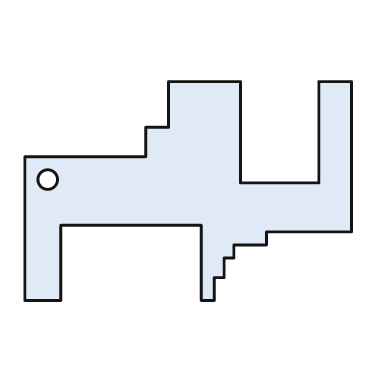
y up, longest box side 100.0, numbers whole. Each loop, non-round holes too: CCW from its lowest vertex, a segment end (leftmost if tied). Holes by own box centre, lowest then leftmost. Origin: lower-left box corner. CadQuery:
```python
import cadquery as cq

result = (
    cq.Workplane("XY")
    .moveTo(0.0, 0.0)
    .lineTo(11.0, 0.0)
    .lineTo(11.0, 23.0)
    .lineTo(54.0, 23.0)
    .lineTo(54.0, 0.0)
    .lineTo(58.0, 0.0)
    .lineTo(58.0, 7.0)
    .lineTo(61.0, 7.0)
    .lineTo(61.0, 13.0)
    .lineTo(64.0, 13.0)
    .lineTo(64.0, 17.0)
    .lineTo(74.0, 17.0)
    .lineTo(74.0, 21.0)
    .lineTo(100.0, 21.0)
    .lineTo(100.0, 67.0)
    .lineTo(90.0, 67.0)
    .lineTo(90.0, 36.0)
    .lineTo(66.0, 36.0)
    .lineTo(66.0, 67.0)
    .lineTo(44.0, 67.0)
    .lineTo(44.0, 53.0)
    .lineTo(37.0, 53.0)
    .lineTo(37.0, 44.0)
    .lineTo(0.0, 44.0)
    .close()
    .moveTo(7.0, 37.0)
    .circle(3.0)
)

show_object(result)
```